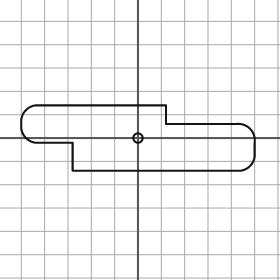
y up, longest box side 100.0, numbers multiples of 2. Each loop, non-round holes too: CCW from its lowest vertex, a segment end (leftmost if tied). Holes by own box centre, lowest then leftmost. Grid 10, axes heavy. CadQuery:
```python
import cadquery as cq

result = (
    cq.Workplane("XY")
    .moveTo(-28.0, -14.0)
    .lineTo(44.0, -14.0)
    .threePointArc((48.0, -12.0), (50.0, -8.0))
    .lineTo(50.0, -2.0)
    .threePointArc((48.0, 4.0), (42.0, 6.0))
    .lineTo(12.0, 6.0)
    .lineTo(12.0, 14.0)
    .lineTo(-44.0, 14.0)
    .threePointArc((-48.0, 12.0), (-50.0, 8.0))
    .lineTo(-50.0, 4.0)
    .threePointArc((-48.0, 0.0), (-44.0, -2.0))
    .lineTo(-28.0, -2.0)
    .close()
    .moveTo(0.0, 0.0)
    .circle(2.0)
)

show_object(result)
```